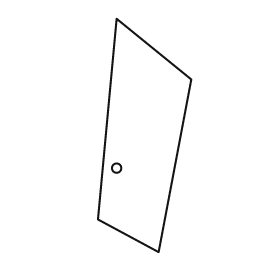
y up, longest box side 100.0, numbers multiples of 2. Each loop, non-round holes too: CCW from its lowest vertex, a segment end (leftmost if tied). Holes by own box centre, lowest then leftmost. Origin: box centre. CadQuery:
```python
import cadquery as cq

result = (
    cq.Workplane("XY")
    .moveTo(6.0, -50.0)
    .lineTo(20.0, 24.0)
    .lineTo(-12.0, 50.0)
    .lineTo(-20.0, -36.0)
    .close()
    .moveTo(-12.0, -14.0)
    .circle(2.0)
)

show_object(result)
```